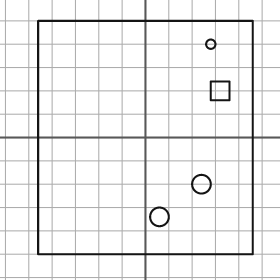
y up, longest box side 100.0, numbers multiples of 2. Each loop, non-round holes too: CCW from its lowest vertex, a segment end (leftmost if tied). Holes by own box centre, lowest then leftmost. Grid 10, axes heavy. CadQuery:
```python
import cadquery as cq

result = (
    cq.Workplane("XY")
    .moveTo(-46.0, -50.0)
    .lineTo(46.0, -50.0)
    .lineTo(46.0, 50.0)
    .lineTo(-46.0, 50.0)
    .close()
    .moveTo(6.0, -34.0)
    .circle(4.0)
    .moveTo(24.0, -20.0)
    .circle(4.0)
    .moveTo(28.0, 16.0)
    .lineTo(36.0, 16.0)
    .lineTo(36.0, 24.0)
    .lineTo(28.0, 24.0)
    .close()
    .moveTo(28.0, 40.0)
    .circle(2.0)
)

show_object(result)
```